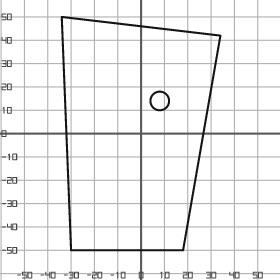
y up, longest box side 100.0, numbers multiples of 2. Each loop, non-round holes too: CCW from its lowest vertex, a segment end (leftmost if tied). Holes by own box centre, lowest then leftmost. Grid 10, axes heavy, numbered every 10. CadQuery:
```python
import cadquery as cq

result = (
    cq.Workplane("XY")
    .moveTo(-30.0, -50.0)
    .lineTo(18.0, -50.0)
    .lineTo(34.0, 42.0)
    .lineTo(-34.0, 50.0)
    .close()
    .moveTo(8.0, 14.0)
    .circle(4.0)
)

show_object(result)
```